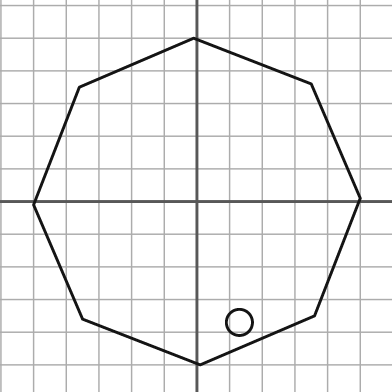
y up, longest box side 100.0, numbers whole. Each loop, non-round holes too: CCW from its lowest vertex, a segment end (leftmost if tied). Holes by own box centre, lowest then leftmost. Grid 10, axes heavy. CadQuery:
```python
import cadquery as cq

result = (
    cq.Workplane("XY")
    .moveTo(1.0, -50.0)
    .lineTo(36.0, -35.0)
    .lineTo(50.0, 1.0)
    .lineTo(35.0, 36.0)
    .lineTo(-1.0, 50.0)
    .lineTo(-36.0, 35.0)
    .lineTo(-50.0, -1.0)
    .lineTo(-35.0, -36.0)
    .close()
    .moveTo(13.0, -37.0)
    .circle(4.0)
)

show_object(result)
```